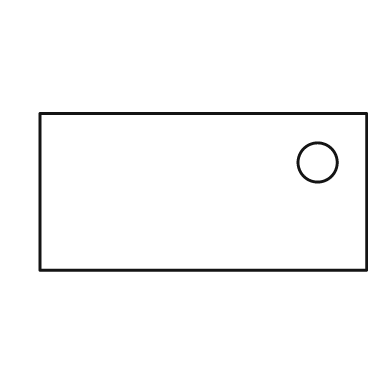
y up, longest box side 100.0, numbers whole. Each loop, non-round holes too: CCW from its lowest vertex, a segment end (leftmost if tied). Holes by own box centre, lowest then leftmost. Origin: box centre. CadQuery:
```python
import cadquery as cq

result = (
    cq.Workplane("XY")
    .moveTo(-50.0, -24.0)
    .lineTo(50.0, -24.0)
    .lineTo(50.0, 24.0)
    .lineTo(-50.0, 24.0)
    .close()
    .moveTo(35.0, 9.0)
    .circle(6.0)
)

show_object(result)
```